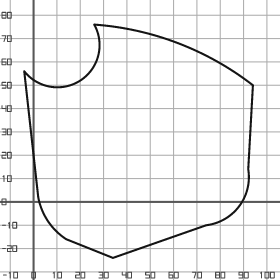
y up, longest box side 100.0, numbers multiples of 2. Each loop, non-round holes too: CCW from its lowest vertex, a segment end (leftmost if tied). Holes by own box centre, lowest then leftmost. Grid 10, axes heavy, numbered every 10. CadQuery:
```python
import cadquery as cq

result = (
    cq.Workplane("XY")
    .moveTo(34.0, -24.0)
    .lineTo(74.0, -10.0)
    .threePointArc((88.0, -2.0), (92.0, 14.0))
    .lineTo(94.0, 50.0)
    .threePointArc((62.0, 68.0), (26.0, 76.0))
    .threePointArc((20.0, 52.0), (-4.0, 56.0))
    .lineTo(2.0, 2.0)
    .threePointArc((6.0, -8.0), (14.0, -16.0))
    .close()
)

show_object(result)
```